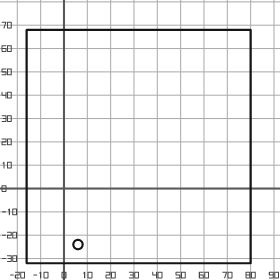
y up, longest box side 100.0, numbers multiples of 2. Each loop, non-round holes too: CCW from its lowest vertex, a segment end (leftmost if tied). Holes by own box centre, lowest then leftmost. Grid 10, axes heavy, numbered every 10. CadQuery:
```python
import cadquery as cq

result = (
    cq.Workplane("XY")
    .moveTo(-16.0, -32.0)
    .lineTo(80.0, -32.0)
    .lineTo(80.0, 68.0)
    .lineTo(-16.0, 68.0)
    .close()
    .moveTo(6.0, -24.0)
    .circle(2.0)
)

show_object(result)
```